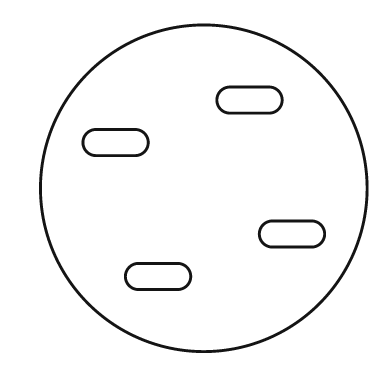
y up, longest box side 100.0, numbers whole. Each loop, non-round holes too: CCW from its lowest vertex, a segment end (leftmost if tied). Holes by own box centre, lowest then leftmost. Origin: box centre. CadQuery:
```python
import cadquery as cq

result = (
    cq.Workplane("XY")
    .moveTo(0.0, 0.0)
    .circle(50.0)
    .moveTo(-20.0, -31.0)
    .lineTo(-8.0, -31.0)
    .threePointArc((-4.0, -27.0), (-8.0, -23.0))
    .lineTo(-20.0, -23.0)
    .threePointArc((-24.0, -27.0), (-20.0, -31.0))
    .close()
    .moveTo(21.0, -18.0)
    .lineTo(33.0, -18.0)
    .threePointArc((37.0, -14.0), (33.0, -10.0))
    .lineTo(21.0, -10.0)
    .threePointArc((17.0, -14.0), (21.0, -18.0))
    .close()
    .moveTo(-33.0, 10.0)
    .lineTo(-21.0, 10.0)
    .threePointArc((-17.0, 14.0), (-21.0, 18.0))
    .lineTo(-33.0, 18.0)
    .threePointArc((-37.0, 14.0), (-33.0, 10.0))
    .close()
    .moveTo(8.0, 23.0)
    .lineTo(20.0, 23.0)
    .threePointArc((24.0, 27.0), (20.0, 31.0))
    .lineTo(8.0, 31.0)
    .threePointArc((4.0, 27.0), (8.0, 23.0))
    .close()
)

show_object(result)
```